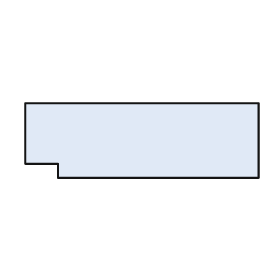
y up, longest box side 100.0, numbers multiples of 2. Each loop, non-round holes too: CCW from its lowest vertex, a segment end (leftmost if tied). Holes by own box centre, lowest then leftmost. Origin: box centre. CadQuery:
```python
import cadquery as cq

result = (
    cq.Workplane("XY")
    .moveTo(-36.0, -16.0)
    .lineTo(50.0, -16.0)
    .lineTo(50.0, 16.0)
    .lineTo(-50.0, 16.0)
    .lineTo(-50.0, -10.0)
    .lineTo(-36.0, -10.0)
    .close()
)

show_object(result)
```